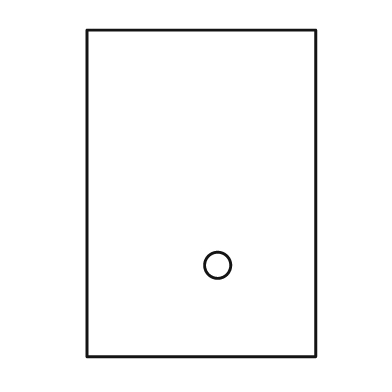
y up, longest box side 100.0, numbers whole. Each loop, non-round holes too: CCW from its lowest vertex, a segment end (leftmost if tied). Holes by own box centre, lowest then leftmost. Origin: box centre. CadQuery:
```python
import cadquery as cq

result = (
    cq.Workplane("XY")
    .moveTo(-35.0, -50.0)
    .lineTo(35.0, -50.0)
    .lineTo(35.0, 50.0)
    .lineTo(-35.0, 50.0)
    .close()
    .moveTo(5.0, -22.0)
    .circle(4.0)
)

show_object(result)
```